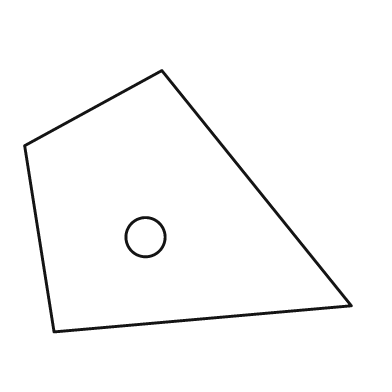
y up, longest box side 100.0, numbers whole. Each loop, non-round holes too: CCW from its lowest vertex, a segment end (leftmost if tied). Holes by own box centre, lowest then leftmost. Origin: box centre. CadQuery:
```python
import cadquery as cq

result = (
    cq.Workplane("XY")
    .moveTo(-41.0, -40.0)
    .lineTo(50.0, -32.0)
    .lineTo(-8.0, 40.0)
    .lineTo(-50.0, 17.0)
    .close()
    .moveTo(-13.0, -11.0)
    .circle(6.0)
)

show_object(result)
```